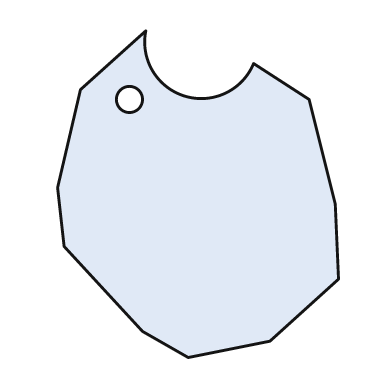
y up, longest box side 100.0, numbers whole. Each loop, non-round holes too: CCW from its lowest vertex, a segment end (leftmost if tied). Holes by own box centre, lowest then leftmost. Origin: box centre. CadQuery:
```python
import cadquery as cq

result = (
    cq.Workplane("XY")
    .moveTo(-3.0, -50.0)
    .lineTo(22.0, -45.0)
    .lineTo(43.0, -26.0)
    .lineTo(42.0, -3.0)
    .lineTo(34.0, 29.0)
    .lineTo(17.0, 40.0)
    .threePointArc((-4.0, 30.0), (-16.0, 50.0))
    .lineTo(-36.0, 32.0)
    .lineTo(-43.0, 2.0)
    .lineTo(-41.0, -16.0)
    .lineTo(-17.0, -42.0)
    .close()
    .moveTo(-21.0, 29.0)
    .circle(4.0)
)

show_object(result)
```